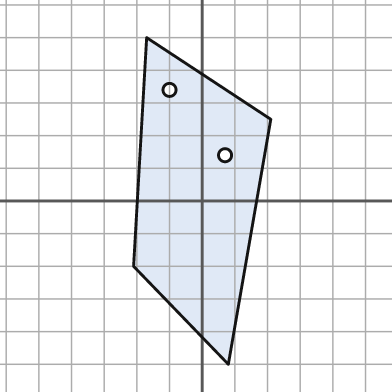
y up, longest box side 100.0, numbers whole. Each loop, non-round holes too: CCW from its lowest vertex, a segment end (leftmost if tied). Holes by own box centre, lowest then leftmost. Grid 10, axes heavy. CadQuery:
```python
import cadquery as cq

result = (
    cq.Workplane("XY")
    .moveTo(8.0, -50.0)
    .lineTo(21.0, 25.0)
    .lineTo(-17.0, 50.0)
    .lineTo(-21.0, -20.0)
    .close()
    .moveTo(7.0, 14.0)
    .circle(2.0)
    .moveTo(-10.0, 34.0)
    .circle(2.0)
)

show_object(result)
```